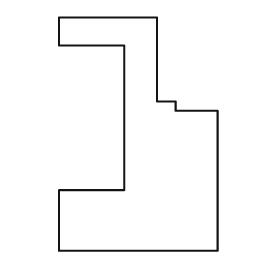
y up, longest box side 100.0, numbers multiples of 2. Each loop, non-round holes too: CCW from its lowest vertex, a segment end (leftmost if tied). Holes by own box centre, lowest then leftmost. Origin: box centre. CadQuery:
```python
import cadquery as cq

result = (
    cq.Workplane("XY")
    .moveTo(-34.0, -50.0)
    .lineTo(34.0, -50.0)
    .lineTo(34.0, 10.0)
    .lineTo(16.0, 10.0)
    .lineTo(16.0, 14.0)
    .lineTo(8.0, 14.0)
    .lineTo(8.0, 50.0)
    .lineTo(-34.0, 50.0)
    .lineTo(-34.0, 38.0)
    .lineTo(-6.0, 38.0)
    .lineTo(-6.0, -24.0)
    .lineTo(-34.0, -24.0)
    .close()
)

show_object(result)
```